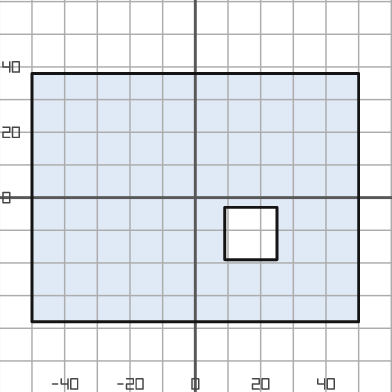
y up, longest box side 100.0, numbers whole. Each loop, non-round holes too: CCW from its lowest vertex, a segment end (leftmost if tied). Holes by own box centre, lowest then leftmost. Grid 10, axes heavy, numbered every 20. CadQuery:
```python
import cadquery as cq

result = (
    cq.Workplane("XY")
    .moveTo(-50.0, -38.0)
    .lineTo(50.0, -38.0)
    .lineTo(50.0, 38.0)
    .lineTo(-50.0, 38.0)
    .close()
    .moveTo(9.0, -19.0)
    .lineTo(25.0, -19.0)
    .lineTo(25.0, -3.0)
    .lineTo(9.0, -3.0)
    .close()
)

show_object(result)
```